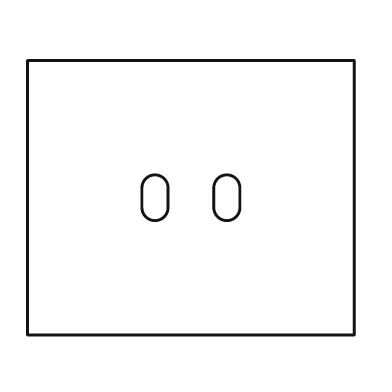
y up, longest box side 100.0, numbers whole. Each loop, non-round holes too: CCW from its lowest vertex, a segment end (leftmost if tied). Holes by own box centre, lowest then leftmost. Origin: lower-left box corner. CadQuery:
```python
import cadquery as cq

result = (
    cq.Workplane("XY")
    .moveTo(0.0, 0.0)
    .lineTo(100.0, 0.0)
    .lineTo(100.0, 84.0)
    .lineTo(0.0, 84.0)
    .close()
    .moveTo(35.0, 39.0)
    .threePointArc((39.0, 35.0), (43.0, 39.0))
    .lineTo(43.0, 45.0)
    .threePointArc((39.0, 49.0), (35.0, 45.0))
    .close()
    .moveTo(57.0, 39.0)
    .threePointArc((61.0, 35.0), (65.0, 39.0))
    .lineTo(65.0, 45.0)
    .threePointArc((61.0, 49.0), (57.0, 45.0))
    .close()
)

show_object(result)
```